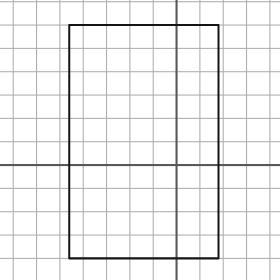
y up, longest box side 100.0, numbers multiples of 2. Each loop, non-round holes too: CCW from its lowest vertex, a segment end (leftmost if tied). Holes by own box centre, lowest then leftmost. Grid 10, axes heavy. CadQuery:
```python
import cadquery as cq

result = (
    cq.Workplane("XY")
    .moveTo(-46.0, -40.0)
    .lineTo(18.0, -40.0)
    .lineTo(18.0, 60.0)
    .lineTo(-46.0, 60.0)
    .close()
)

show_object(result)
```